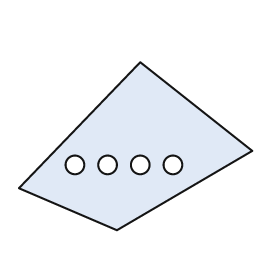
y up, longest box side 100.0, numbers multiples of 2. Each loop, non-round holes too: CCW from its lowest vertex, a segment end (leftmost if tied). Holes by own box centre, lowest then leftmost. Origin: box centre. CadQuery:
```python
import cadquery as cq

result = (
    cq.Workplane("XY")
    .moveTo(-8.0, -36.0)
    .lineTo(50.0, -2.0)
    .lineTo(2.0, 36.0)
    .lineTo(-50.0, -18.0)
    .close()
    .moveTo(-26.0, -8.0)
    .circle(4.0)
    .moveTo(-12.0, -8.0)
    .circle(4.0)
    .moveTo(2.0, -8.0)
    .circle(4.0)
    .moveTo(16.0, -8.0)
    .circle(4.0)
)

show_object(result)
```